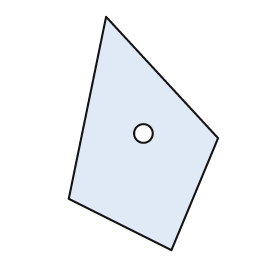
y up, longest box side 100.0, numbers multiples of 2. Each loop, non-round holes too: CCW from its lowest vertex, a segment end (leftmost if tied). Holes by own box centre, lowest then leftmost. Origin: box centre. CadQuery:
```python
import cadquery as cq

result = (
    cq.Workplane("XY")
    .moveTo(12.0, -50.0)
    .lineTo(32.0, -2.0)
    .lineTo(-16.0, 50.0)
    .lineTo(-32.0, -28.0)
    .close()
    .moveTo(0.0, 0.0)
    .circle(4.0)
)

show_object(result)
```